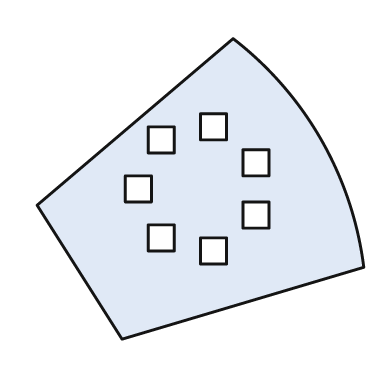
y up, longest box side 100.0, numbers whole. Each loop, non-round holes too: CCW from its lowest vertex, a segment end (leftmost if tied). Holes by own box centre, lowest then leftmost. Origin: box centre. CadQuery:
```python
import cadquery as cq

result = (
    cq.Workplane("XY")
    .moveTo(-24.0, -46.0)
    .lineTo(50.0, -24.0)
    .threePointArc((37.0, 15.0), (10.0, 46.0))
    .lineTo(-50.0, -5.0)
    .close()
    .moveTo(0.0, -23.0)
    .lineTo(8.0, -23.0)
    .lineTo(8.0, -15.0)
    .lineTo(0.0, -15.0)
    .close()
    .moveTo(-16.0, -19.0)
    .lineTo(-8.0, -19.0)
    .lineTo(-8.0, -11.0)
    .lineTo(-16.0, -11.0)
    .close()
    .moveTo(13.0, -12.0)
    .lineTo(21.0, -12.0)
    .lineTo(21.0, -4.0)
    .lineTo(13.0, -4.0)
    .close()
    .moveTo(-23.0, -4.0)
    .lineTo(-15.0, -4.0)
    .lineTo(-15.0, 4.0)
    .lineTo(-23.0, 4.0)
    .close()
    .moveTo(13.0, 4.0)
    .lineTo(21.0, 4.0)
    .lineTo(21.0, 12.0)
    .lineTo(13.0, 12.0)
    .close()
    .moveTo(-16.0, 11.0)
    .lineTo(-8.0, 11.0)
    .lineTo(-8.0, 19.0)
    .lineTo(-16.0, 19.0)
    .close()
    .moveTo(0.0, 15.0)
    .lineTo(8.0, 15.0)
    .lineTo(8.0, 23.0)
    .lineTo(0.0, 23.0)
    .close()
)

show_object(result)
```